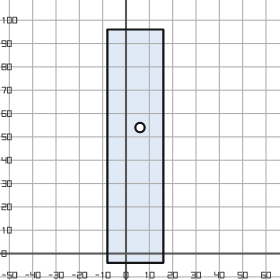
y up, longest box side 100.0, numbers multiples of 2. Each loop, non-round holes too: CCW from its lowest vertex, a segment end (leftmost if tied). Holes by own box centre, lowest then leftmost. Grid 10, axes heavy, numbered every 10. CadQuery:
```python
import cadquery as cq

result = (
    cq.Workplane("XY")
    .moveTo(-8.0, -4.0)
    .lineTo(16.0, -4.0)
    .lineTo(16.0, 96.0)
    .lineTo(-8.0, 96.0)
    .close()
    .moveTo(6.0, 54.0)
    .circle(2.0)
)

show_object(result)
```